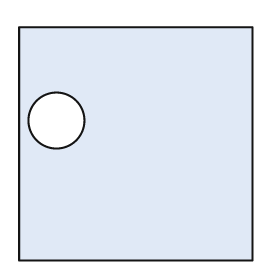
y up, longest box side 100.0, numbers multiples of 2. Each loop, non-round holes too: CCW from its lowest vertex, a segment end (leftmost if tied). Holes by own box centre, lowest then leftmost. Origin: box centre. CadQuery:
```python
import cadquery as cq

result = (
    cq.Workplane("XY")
    .moveTo(-50.0, -50.0)
    .lineTo(50.0, -50.0)
    .lineTo(50.0, 50.0)
    .lineTo(-50.0, 50.0)
    .close()
    .moveTo(-34.0, 10.0)
    .circle(12.0)
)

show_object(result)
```